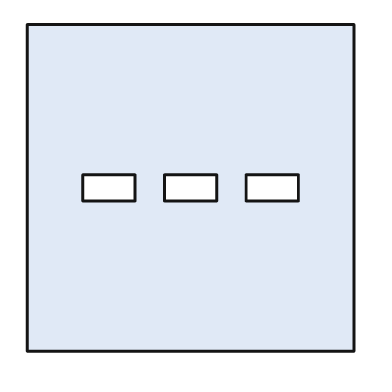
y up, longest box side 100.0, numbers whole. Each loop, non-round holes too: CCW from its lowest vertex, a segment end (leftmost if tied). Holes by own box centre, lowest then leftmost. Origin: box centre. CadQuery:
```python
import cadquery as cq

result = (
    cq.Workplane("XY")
    .moveTo(-50.0, -50.0)
    .lineTo(50.0, -50.0)
    .lineTo(50.0, 50.0)
    .lineTo(-50.0, 50.0)
    .close()
    .moveTo(-33.0, -4.0)
    .lineTo(-17.0, -4.0)
    .lineTo(-17.0, 4.0)
    .lineTo(-33.0, 4.0)
    .close()
    .moveTo(-8.0, -4.0)
    .lineTo(8.0, -4.0)
    .lineTo(8.0, 4.0)
    .lineTo(-8.0, 4.0)
    .close()
    .moveTo(17.0, -4.0)
    .lineTo(33.0, -4.0)
    .lineTo(33.0, 4.0)
    .lineTo(17.0, 4.0)
    .close()
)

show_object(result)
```